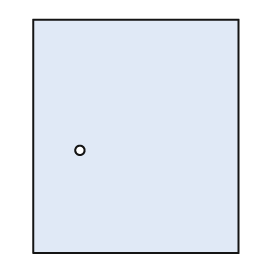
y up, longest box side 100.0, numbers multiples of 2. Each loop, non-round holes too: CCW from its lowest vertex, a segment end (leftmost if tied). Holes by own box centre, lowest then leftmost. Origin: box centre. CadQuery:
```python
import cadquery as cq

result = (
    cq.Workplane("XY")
    .moveTo(-44.0, -50.0)
    .lineTo(44.0, -50.0)
    .lineTo(44.0, 50.0)
    .lineTo(-44.0, 50.0)
    .close()
    .moveTo(-24.0, -6.0)
    .circle(2.0)
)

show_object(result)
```